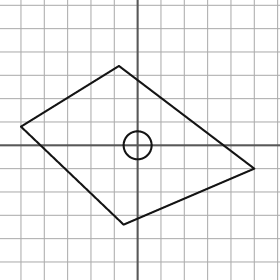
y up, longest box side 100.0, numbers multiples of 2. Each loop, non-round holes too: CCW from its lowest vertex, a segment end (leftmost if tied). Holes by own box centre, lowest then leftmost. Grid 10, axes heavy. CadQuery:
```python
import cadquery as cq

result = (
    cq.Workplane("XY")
    .moveTo(-6.0, -34.0)
    .lineTo(50.0, -10.0)
    .lineTo(-8.0, 34.0)
    .lineTo(-50.0, 8.0)
    .close()
    .moveTo(0.0, 0.0)
    .circle(6.0)
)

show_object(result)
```